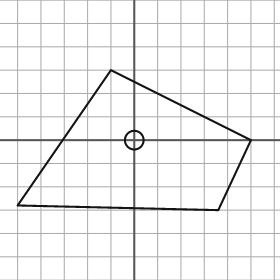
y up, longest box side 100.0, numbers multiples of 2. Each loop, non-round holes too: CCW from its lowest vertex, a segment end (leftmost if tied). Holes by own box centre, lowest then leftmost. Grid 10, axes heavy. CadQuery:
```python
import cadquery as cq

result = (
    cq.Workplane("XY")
    .moveTo(36.0, -30.0)
    .lineTo(50.0, 0.0)
    .lineTo(-10.0, 30.0)
    .lineTo(-50.0, -28.0)
    .close()
    .moveTo(0.0, 0.0)
    .circle(4.0)
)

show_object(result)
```